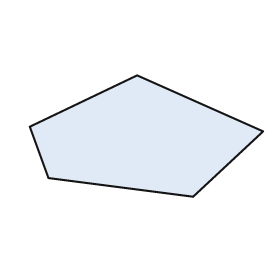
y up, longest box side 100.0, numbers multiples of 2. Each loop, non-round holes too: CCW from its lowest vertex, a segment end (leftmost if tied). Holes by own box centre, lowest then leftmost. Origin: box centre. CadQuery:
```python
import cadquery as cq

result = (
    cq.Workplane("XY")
    .moveTo(20.0, -26.0)
    .lineTo(50.0, 2.0)
    .lineTo(-4.0, 26.0)
    .lineTo(-50.0, 4.0)
    .lineTo(-42.0, -18.0)
    .close()
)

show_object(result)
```